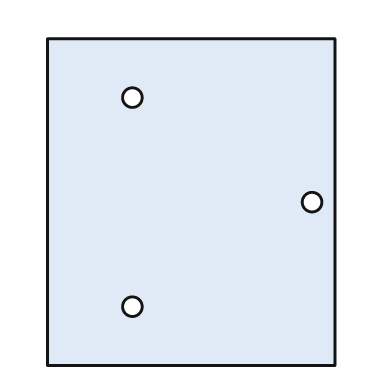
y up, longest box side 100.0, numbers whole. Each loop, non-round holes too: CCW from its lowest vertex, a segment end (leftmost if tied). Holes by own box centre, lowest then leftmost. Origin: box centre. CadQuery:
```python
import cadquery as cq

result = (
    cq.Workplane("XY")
    .moveTo(-44.0, -50.0)
    .lineTo(44.0, -50.0)
    .lineTo(44.0, 50.0)
    .lineTo(-44.0, 50.0)
    .close()
    .moveTo(-18.0, -32.0)
    .circle(3.0)
    .moveTo(37.0, 0.0)
    .circle(3.0)
    .moveTo(-18.0, 32.0)
    .circle(3.0)
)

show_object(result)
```